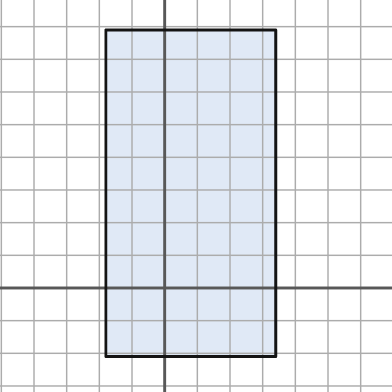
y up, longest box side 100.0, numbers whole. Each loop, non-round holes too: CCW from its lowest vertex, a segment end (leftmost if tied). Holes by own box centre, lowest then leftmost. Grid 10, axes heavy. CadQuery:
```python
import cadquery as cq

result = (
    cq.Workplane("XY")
    .moveTo(-18.0, -21.0)
    .lineTo(34.0, -21.0)
    .lineTo(34.0, 79.0)
    .lineTo(-18.0, 79.0)
    .close()
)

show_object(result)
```